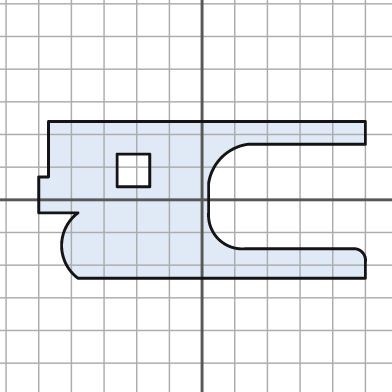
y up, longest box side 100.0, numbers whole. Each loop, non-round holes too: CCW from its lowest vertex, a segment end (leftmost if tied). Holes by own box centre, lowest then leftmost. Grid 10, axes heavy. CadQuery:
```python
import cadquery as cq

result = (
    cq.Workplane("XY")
    .moveTo(-38.0, -24.0)
    .lineTo(50.0, -24.0)
    .lineTo(50.0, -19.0)
    .threePointArc((49.0, -16.0), (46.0, -15.0))
    .lineTo(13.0, -15.0)
    .threePointArc((5.0, -12.0), (2.0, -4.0))
    .lineTo(2.0, 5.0)
    .threePointArc((6.0, 13.0), (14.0, 17.0))
    .lineTo(50.0, 17.0)
    .lineTo(50.0, 24.0)
    .lineTo(-47.0, 24.0)
    .lineTo(-47.0, 7.0)
    .lineTo(-50.0, 7.0)
    .lineTo(-50.0, -4.0)
    .lineTo(-38.0, -4.0)
    .threePointArc((-43.0, -14.0), (-38.0, -24.0))
    .close()
    .moveTo(-26.0, 4.0)
    .lineTo(-16.0, 4.0)
    .lineTo(-16.0, 14.0)
    .lineTo(-26.0, 14.0)
    .close()
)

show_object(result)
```